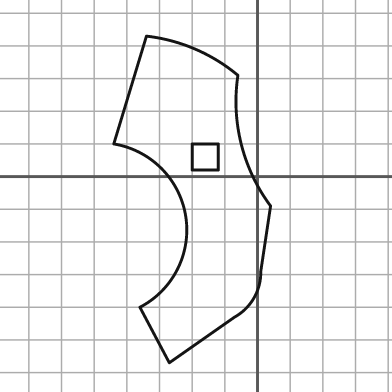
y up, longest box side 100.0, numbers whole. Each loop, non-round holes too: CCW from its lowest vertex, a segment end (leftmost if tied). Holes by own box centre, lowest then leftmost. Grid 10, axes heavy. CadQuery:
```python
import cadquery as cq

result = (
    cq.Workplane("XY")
    .moveTo(-27.0, -57.0)
    .lineTo(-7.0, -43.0)
    .threePointArc((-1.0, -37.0), (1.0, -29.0))
    .lineTo(4.0, -9.0)
    .threePointArc((-5.0, 10.0), (-6.0, 31.0))
    .threePointArc((-19.0, 39.0), (-34.0, 43.0))
    .lineTo(-44.0, 10.0)
    .threePointArc((-22.0, -12.0), (-36.0, -40.0))
    .close()
    .moveTo(-20.0, 2.0)
    .lineTo(-12.0, 2.0)
    .lineTo(-12.0, 10.0)
    .lineTo(-20.0, 10.0)
    .close()
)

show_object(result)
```